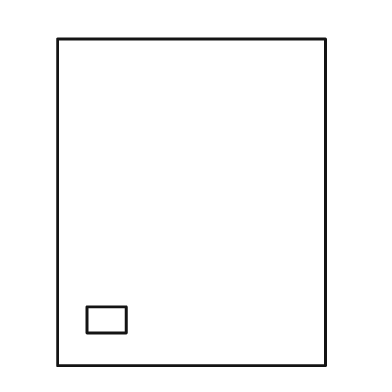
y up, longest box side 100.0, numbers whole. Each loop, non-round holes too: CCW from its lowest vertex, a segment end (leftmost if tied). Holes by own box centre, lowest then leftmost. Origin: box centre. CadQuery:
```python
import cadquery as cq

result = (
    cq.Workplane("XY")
    .moveTo(-41.0, -50.0)
    .lineTo(41.0, -50.0)
    .lineTo(41.0, 50.0)
    .lineTo(-41.0, 50.0)
    .close()
    .moveTo(-32.0, -40.0)
    .lineTo(-20.0, -40.0)
    .lineTo(-20.0, -32.0)
    .lineTo(-32.0, -32.0)
    .close()
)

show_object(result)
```